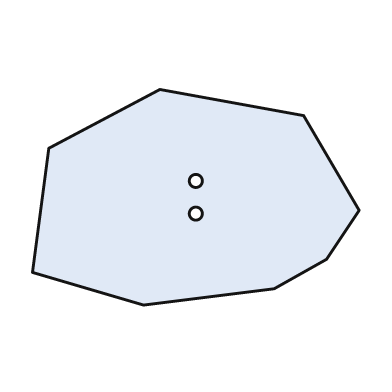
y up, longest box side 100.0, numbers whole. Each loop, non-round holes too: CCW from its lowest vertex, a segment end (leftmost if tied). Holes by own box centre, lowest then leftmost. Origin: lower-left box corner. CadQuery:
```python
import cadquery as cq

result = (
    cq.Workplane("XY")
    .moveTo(34.0, 0.0)
    .lineTo(74.0, 5.0)
    .lineTo(90.0, 14.0)
    .lineTo(100.0, 29.0)
    .lineTo(83.0, 58.0)
    .lineTo(39.0, 66.0)
    .lineTo(5.0, 48.0)
    .lineTo(0.0, 10.0)
    .close()
    .moveTo(50.0, 28.0)
    .circle(2.0)
    .moveTo(50.0, 38.0)
    .circle(2.0)
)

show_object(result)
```